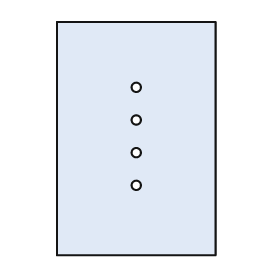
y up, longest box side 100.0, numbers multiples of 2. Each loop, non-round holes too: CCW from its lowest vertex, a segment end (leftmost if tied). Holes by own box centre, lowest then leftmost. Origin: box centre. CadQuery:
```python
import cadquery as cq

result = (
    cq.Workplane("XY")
    .moveTo(-34.0, -50.0)
    .lineTo(34.0, -50.0)
    .lineTo(34.0, 50.0)
    .lineTo(-34.0, 50.0)
    .close()
    .moveTo(0.0, -20.0)
    .circle(2.0)
    .moveTo(0.0, -6.0)
    .circle(2.0)
    .moveTo(0.0, 8.0)
    .circle(2.0)
    .moveTo(0.0, 22.0)
    .circle(2.0)
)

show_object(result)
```